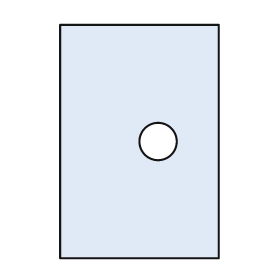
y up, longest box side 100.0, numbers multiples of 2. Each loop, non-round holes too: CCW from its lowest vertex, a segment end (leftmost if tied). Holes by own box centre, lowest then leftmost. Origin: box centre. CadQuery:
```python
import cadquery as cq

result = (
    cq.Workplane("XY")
    .moveTo(-34.0, -50.0)
    .lineTo(34.0, -50.0)
    .lineTo(34.0, 50.0)
    .lineTo(-34.0, 50.0)
    .close()
    .moveTo(8.0, 0.0)
    .circle(8.0)
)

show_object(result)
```